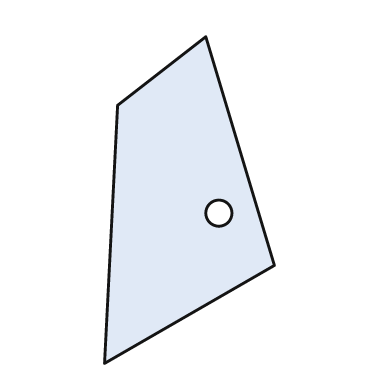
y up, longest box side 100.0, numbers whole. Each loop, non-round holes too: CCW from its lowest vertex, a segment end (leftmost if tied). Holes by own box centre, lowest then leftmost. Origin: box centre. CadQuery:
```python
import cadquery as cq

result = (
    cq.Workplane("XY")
    .moveTo(-26.0, -50.0)
    .lineTo(26.0, -20.0)
    .lineTo(5.0, 50.0)
    .lineTo(-22.0, 29.0)
    .close()
    .moveTo(9.0, -4.0)
    .circle(4.0)
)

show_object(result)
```